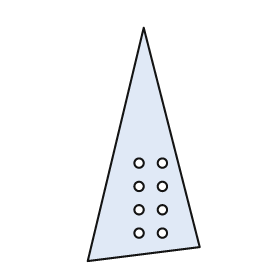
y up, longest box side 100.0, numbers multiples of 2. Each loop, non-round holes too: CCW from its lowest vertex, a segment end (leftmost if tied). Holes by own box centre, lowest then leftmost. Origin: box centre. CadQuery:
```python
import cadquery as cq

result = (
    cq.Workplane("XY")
    .moveTo(-24.0, -50.0)
    .lineTo(24.0, -44.0)
    .lineTo(0.0, 50.0)
    .close()
    .moveTo(-2.0, -38.0)
    .circle(2.0)
    .moveTo(8.0, -38.0)
    .circle(2.0)
    .moveTo(-2.0, -28.0)
    .circle(2.0)
    .moveTo(8.0, -28.0)
    .circle(2.0)
    .moveTo(-2.0, -18.0)
    .circle(2.0)
    .moveTo(8.0, -18.0)
    .circle(2.0)
    .moveTo(-2.0, -8.0)
    .circle(2.0)
    .moveTo(8.0, -8.0)
    .circle(2.0)
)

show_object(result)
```